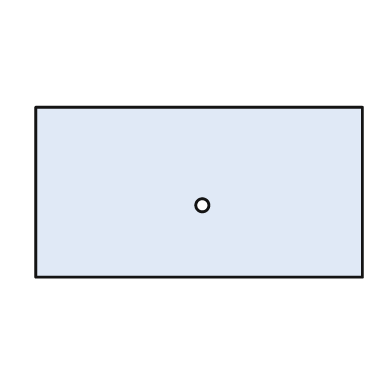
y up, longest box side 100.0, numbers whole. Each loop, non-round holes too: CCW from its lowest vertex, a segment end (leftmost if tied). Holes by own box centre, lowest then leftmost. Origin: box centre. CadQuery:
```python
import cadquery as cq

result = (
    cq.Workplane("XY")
    .moveTo(-50.0, -26.0)
    .lineTo(50.0, -26.0)
    .lineTo(50.0, 26.0)
    .lineTo(-50.0, 26.0)
    .close()
    .moveTo(1.0, -4.0)
    .circle(2.0)
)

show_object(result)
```